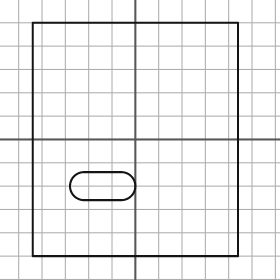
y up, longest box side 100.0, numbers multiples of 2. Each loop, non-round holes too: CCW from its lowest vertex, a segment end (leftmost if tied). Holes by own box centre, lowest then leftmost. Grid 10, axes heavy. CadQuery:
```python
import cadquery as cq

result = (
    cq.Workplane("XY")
    .moveTo(-44.0, -50.0)
    .lineTo(44.0, -50.0)
    .lineTo(44.0, 50.0)
    .lineTo(-44.0, 50.0)
    .close()
    .moveTo(-22.0, -26.0)
    .lineTo(-6.0, -26.0)
    .threePointArc((0.0, -20.0), (-6.0, -14.0))
    .lineTo(-22.0, -14.0)
    .threePointArc((-28.0, -20.0), (-22.0, -26.0))
    .close()
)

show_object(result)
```